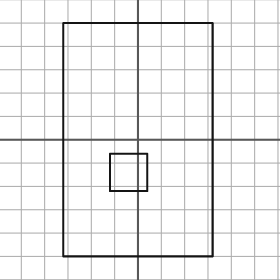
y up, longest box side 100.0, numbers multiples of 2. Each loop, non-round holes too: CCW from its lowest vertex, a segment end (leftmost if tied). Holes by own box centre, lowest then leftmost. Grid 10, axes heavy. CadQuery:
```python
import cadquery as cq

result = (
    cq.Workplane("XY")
    .moveTo(-32.0, -50.0)
    .lineTo(32.0, -50.0)
    .lineTo(32.0, 50.0)
    .lineTo(-32.0, 50.0)
    .close()
    .moveTo(-12.0, -22.0)
    .lineTo(4.0, -22.0)
    .lineTo(4.0, -6.0)
    .lineTo(-12.0, -6.0)
    .close()
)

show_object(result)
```